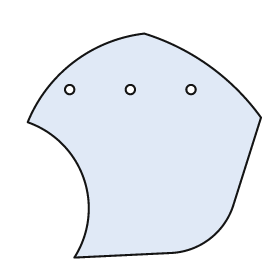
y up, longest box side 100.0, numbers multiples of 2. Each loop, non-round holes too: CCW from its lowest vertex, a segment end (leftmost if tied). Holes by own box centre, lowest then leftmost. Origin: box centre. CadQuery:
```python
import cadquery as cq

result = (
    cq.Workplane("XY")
    .moveTo(-30.0, -48.0)
    .lineTo(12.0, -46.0)
    .threePointArc((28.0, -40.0), (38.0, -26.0))
    .lineTo(50.0, 12.0)
    .threePointArc((28.0, 34.0), (0.0, 48.0))
    .threePointArc((-30.0, 36.0), (-50.0, 10.0))
    .threePointArc((-26.0, -14.0), (-30.0, -48.0))
    .close()
    .moveTo(-32.0, 24.0)
    .circle(2.0)
    .moveTo(-6.0, 24.0)
    .circle(2.0)
    .moveTo(20.0, 24.0)
    .circle(2.0)
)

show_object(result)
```